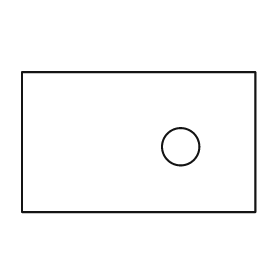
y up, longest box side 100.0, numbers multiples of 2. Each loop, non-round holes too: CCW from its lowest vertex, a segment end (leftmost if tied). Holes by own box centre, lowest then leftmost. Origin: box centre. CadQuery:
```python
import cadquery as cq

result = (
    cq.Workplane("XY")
    .moveTo(-50.0, -30.0)
    .lineTo(50.0, -30.0)
    .lineTo(50.0, 30.0)
    .lineTo(-50.0, 30.0)
    .close()
    .moveTo(18.0, -2.0)
    .circle(8.0)
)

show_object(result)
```